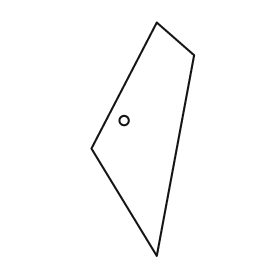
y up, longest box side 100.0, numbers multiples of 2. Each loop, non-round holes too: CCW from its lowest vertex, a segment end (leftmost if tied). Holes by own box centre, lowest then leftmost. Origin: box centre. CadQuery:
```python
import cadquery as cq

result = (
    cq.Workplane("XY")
    .moveTo(6.0, -50.0)
    .lineTo(22.0, 36.0)
    .lineTo(6.0, 50.0)
    .lineTo(-22.0, -4.0)
    .close()
    .moveTo(-8.0, 8.0)
    .circle(2.0)
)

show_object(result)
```